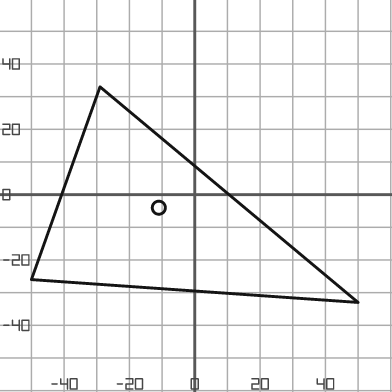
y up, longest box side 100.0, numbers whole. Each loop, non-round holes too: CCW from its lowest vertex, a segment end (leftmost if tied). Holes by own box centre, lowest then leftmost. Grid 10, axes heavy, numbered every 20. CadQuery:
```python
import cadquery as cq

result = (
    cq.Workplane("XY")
    .moveTo(50.0, -33.0)
    .lineTo(-29.0, 33.0)
    .lineTo(-50.0, -26.0)
    .close()
    .moveTo(-11.0, -4.0)
    .circle(2.0)
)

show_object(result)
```